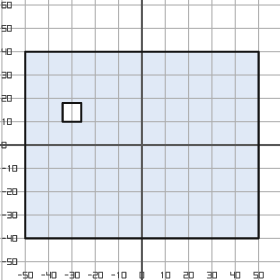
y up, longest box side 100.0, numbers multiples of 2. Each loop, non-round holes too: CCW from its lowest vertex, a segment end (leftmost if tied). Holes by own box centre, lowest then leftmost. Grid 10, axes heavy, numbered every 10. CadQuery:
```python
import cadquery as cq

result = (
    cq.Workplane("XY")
    .moveTo(-50.0, -40.0)
    .lineTo(50.0, -40.0)
    .lineTo(50.0, 40.0)
    .lineTo(-50.0, 40.0)
    .close()
    .moveTo(-34.0, 10.0)
    .lineTo(-26.0, 10.0)
    .lineTo(-26.0, 18.0)
    .lineTo(-34.0, 18.0)
    .close()
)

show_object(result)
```